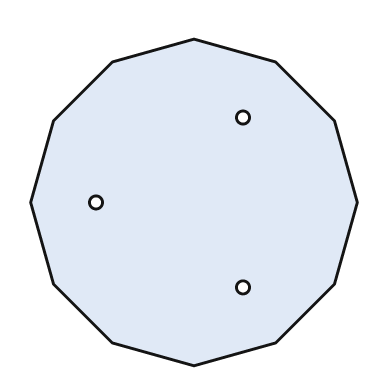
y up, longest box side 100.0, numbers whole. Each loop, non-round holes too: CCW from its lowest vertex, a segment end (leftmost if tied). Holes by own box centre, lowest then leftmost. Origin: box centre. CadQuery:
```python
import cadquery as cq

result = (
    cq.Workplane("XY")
    .moveTo(0.0, -50.0)
    .lineTo(25.0, -43.0)
    .lineTo(43.0, -25.0)
    .lineTo(50.0, 0.0)
    .lineTo(43.0, 25.0)
    .lineTo(25.0, 43.0)
    .lineTo(0.0, 50.0)
    .lineTo(-25.0, 43.0)
    .lineTo(-43.0, 25.0)
    .lineTo(-50.0, 0.0)
    .lineTo(-43.0, -25.0)
    .lineTo(-25.0, -43.0)
    .close()
    .moveTo(15.0, -26.0)
    .circle(2.0)
    .moveTo(-30.0, 0.0)
    .circle(2.0)
    .moveTo(15.0, 26.0)
    .circle(2.0)
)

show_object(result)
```